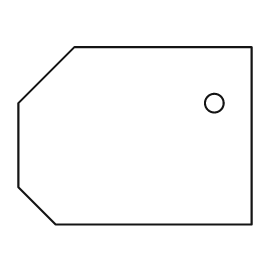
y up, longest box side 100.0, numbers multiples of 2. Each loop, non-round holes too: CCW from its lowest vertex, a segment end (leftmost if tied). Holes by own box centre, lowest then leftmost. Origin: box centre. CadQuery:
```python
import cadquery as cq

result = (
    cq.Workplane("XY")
    .moveTo(-34.0, -38.0)
    .lineTo(50.0, -38.0)
    .lineTo(50.0, 38.0)
    .lineTo(-26.0, 38.0)
    .lineTo(-50.0, 14.0)
    .lineTo(-50.0, -22.0)
    .close()
    .moveTo(34.0, 14.0)
    .circle(4.0)
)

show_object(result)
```